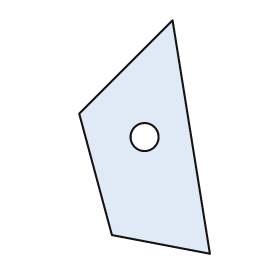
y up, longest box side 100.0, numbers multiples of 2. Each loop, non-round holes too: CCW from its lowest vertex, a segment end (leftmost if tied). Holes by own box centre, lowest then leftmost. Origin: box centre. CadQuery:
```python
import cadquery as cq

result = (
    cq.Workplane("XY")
    .moveTo(28.0, -50.0)
    .lineTo(12.0, 50.0)
    .lineTo(-28.0, 10.0)
    .lineTo(-14.0, -42.0)
    .close()
    .moveTo(0.0, 0.0)
    .circle(6.0)
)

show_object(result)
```